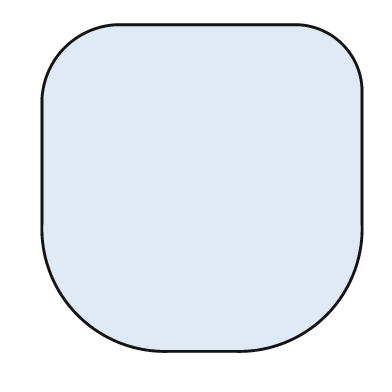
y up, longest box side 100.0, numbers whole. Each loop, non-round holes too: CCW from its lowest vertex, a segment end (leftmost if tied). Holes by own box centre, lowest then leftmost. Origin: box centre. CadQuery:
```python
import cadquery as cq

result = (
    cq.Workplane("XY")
    .moveTo(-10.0, -50.0)
    .lineTo(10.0, -50.0)
    .threePointArc((38.0, -39.0), (49.0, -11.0))
    .lineTo(49.0, 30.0)
    .threePointArc((43.0, 44.0), (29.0, 50.0))
    .lineTo(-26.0, 50.0)
    .threePointArc((-42.0, 43.0), (-49.0, 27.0))
    .lineTo(-49.0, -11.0)
    .threePointArc((-38.0, -39.0), (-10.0, -50.0))
    .close()
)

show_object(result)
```